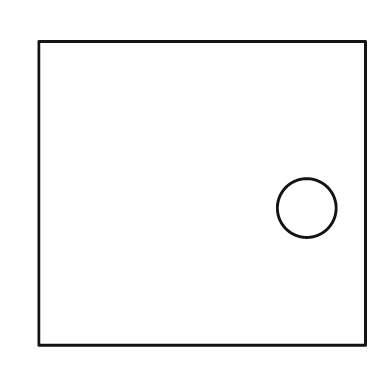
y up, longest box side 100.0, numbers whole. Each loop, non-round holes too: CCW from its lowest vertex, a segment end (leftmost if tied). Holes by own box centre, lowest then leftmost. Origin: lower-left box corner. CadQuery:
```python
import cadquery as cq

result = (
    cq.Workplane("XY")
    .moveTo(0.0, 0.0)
    .lineTo(100.0, 0.0)
    .lineTo(100.0, 93.0)
    .lineTo(0.0, 93.0)
    .close()
    .moveTo(82.0, 42.0)
    .circle(9.0)
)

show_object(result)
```